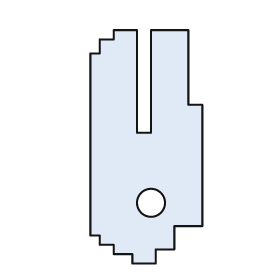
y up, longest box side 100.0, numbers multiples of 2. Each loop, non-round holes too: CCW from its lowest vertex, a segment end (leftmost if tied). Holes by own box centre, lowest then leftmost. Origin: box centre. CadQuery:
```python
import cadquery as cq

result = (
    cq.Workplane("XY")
    .moveTo(-6.0, -50.0)
    .lineTo(4.0, -50.0)
    .lineTo(4.0, -44.0)
    .lineTo(12.0, -44.0)
    .lineTo(12.0, -34.0)
    .lineTo(24.0, -34.0)
    .lineTo(24.0, 18.0)
    .lineTo(18.0, 18.0)
    .lineTo(18.0, 50.0)
    .lineTo(2.0, 50.0)
    .lineTo(2.0, 6.0)
    .lineTo(-4.0, 6.0)
    .lineTo(-4.0, 50.0)
    .lineTo(-14.0, 50.0)
    .lineTo(-14.0, 46.0)
    .lineTo(-20.0, 46.0)
    .lineTo(-20.0, 40.0)
    .lineTo(-24.0, 40.0)
    .lineTo(-24.0, -38.0)
    .lineTo(-20.0, -38.0)
    .lineTo(-20.0, -42.0)
    .lineTo(-14.0, -42.0)
    .lineTo(-14.0, -46.0)
    .lineTo(-6.0, -46.0)
    .close()
    .moveTo(2.0, -24.0)
    .circle(6.0)
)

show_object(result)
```